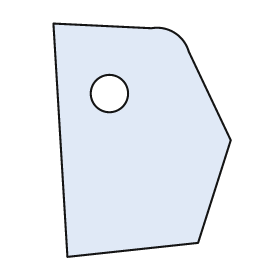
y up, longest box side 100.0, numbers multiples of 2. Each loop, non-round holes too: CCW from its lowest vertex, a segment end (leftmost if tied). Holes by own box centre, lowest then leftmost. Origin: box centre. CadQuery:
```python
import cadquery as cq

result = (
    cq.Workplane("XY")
    .moveTo(-32.0, -50.0)
    .lineTo(24.0, -44.0)
    .lineTo(38.0, 0.0)
    .lineTo(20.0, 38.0)
    .threePointArc((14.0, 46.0), (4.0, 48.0))
    .lineTo(-38.0, 50.0)
    .close()
    .moveTo(-14.0, 20.0)
    .circle(8.0)
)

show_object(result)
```